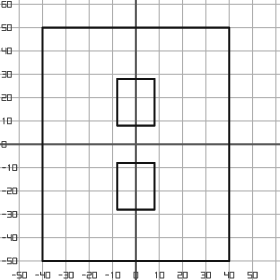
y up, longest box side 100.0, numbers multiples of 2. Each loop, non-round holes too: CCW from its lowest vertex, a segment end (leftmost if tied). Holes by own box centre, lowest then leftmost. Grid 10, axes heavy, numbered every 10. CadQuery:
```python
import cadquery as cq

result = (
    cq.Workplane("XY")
    .moveTo(-40.0, -50.0)
    .lineTo(40.0, -50.0)
    .lineTo(40.0, 50.0)
    .lineTo(-40.0, 50.0)
    .close()
    .moveTo(-8.0, -28.0)
    .lineTo(8.0, -28.0)
    .lineTo(8.0, -8.0)
    .lineTo(-8.0, -8.0)
    .close()
    .moveTo(-8.0, 8.0)
    .lineTo(8.0, 8.0)
    .lineTo(8.0, 28.0)
    .lineTo(-8.0, 28.0)
    .close()
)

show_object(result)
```